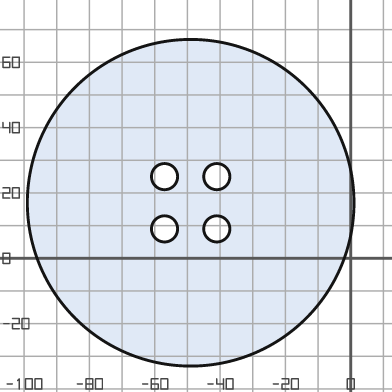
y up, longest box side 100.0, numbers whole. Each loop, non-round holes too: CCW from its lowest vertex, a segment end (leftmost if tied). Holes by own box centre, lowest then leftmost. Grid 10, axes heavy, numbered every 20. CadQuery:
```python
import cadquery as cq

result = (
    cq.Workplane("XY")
    .moveTo(-49.0, 17.0)
    .circle(50.0)
    .moveTo(-57.0, 9.0)
    .circle(4.0)
    .moveTo(-41.0, 9.0)
    .circle(4.0)
    .moveTo(-57.0, 25.0)
    .circle(4.0)
    .moveTo(-41.0, 25.0)
    .circle(4.0)
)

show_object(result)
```